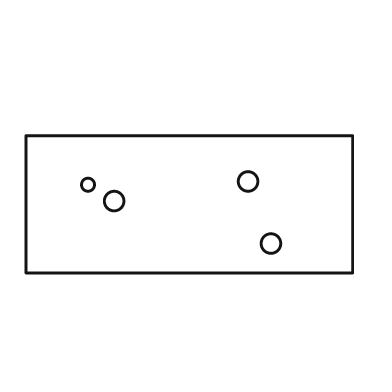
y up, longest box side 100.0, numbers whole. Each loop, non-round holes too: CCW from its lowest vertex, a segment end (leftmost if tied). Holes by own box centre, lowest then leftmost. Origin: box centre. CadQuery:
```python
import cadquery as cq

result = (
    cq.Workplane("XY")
    .moveTo(-50.0, -21.0)
    .lineTo(50.0, -21.0)
    .lineTo(50.0, 21.0)
    .lineTo(-50.0, 21.0)
    .close()
    .moveTo(25.0, -12.0)
    .circle(3.0)
    .moveTo(-23.0, 1.0)
    .circle(3.0)
    .moveTo(-31.0, 6.0)
    .circle(2.0)
    .moveTo(18.0, 7.0)
    .circle(3.0)
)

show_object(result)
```